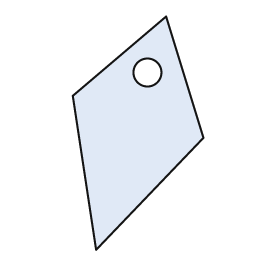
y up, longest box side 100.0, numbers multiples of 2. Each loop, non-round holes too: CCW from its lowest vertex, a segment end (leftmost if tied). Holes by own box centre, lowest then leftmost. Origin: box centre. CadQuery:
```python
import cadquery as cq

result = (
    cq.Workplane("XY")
    .moveTo(-18.0, -50.0)
    .lineTo(28.0, -2.0)
    .lineTo(12.0, 50.0)
    .lineTo(-28.0, 16.0)
    .close()
    .moveTo(4.0, 26.0)
    .circle(6.0)
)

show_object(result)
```